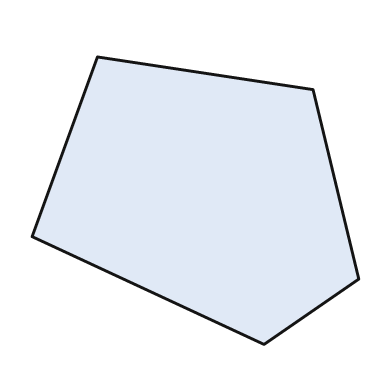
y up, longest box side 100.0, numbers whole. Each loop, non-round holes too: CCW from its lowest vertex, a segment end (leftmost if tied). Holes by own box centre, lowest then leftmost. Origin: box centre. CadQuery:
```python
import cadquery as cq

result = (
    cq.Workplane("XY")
    .moveTo(21.0, -44.0)
    .lineTo(50.0, -24.0)
    .lineTo(36.0, 34.0)
    .lineTo(-30.0, 44.0)
    .lineTo(-50.0, -11.0)
    .close()
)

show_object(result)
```